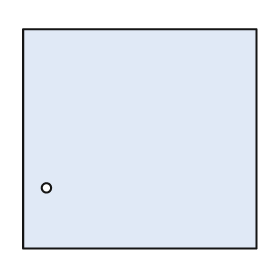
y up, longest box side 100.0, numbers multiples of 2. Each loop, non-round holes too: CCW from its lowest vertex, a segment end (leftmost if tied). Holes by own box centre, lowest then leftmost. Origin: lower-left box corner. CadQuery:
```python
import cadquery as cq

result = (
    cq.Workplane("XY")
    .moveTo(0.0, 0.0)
    .lineTo(100.0, 0.0)
    .lineTo(100.0, 94.0)
    .lineTo(0.0, 94.0)
    .close()
    .moveTo(10.0, 26.0)
    .circle(2.0)
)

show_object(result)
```